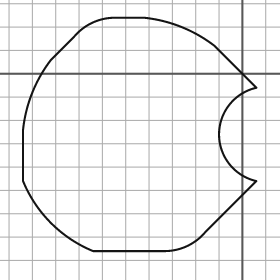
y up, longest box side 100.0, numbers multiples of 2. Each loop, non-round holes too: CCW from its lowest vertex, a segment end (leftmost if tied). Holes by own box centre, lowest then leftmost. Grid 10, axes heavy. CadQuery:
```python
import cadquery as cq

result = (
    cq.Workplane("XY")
    .moveTo(-64.0, -76.0)
    .lineTo(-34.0, -76.0)
    .threePointArc((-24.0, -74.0), (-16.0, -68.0))
    .lineTo(6.0, -46.0)
    .threePointArc((-10.0, -26.0), (6.0, -6.0))
    .lineTo(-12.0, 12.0)
    .threePointArc((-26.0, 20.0), (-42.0, 24.0))
    .lineTo(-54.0, 24.0)
    .threePointArc((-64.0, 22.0), (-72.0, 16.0))
    .lineTo(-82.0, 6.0)
    .threePointArc((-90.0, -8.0), (-94.0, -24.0))
    .lineTo(-94.0, -46.0)
    .threePointArc((-82.0, -64.0), (-64.0, -76.0))
    .close()
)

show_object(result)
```